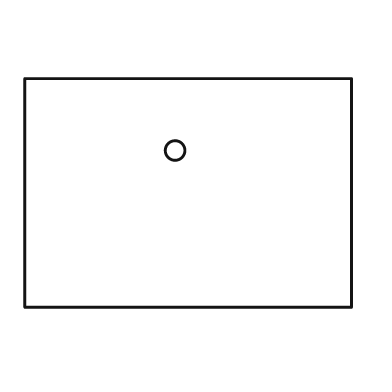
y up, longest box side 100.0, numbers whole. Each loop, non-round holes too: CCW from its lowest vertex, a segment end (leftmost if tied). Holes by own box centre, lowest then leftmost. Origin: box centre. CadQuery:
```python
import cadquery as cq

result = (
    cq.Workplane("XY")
    .moveTo(-50.0, -35.0)
    .lineTo(50.0, -35.0)
    .lineTo(50.0, 35.0)
    .lineTo(-50.0, 35.0)
    .close()
    .moveTo(-4.0, 13.0)
    .circle(3.0)
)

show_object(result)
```